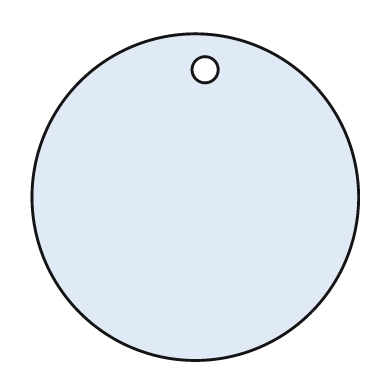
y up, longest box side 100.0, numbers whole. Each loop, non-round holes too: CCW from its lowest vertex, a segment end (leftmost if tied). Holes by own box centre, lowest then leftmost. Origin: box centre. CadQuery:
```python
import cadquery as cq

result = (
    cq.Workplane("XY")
    .moveTo(0.0, 0.0)
    .circle(50.0)
    .moveTo(3.0, 39.0)
    .circle(4.0)
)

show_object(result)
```